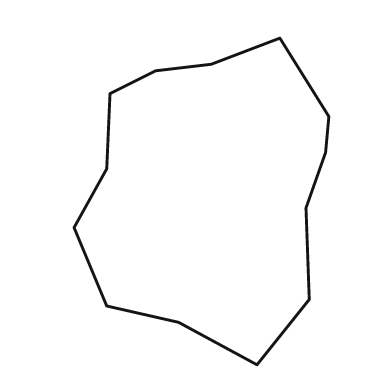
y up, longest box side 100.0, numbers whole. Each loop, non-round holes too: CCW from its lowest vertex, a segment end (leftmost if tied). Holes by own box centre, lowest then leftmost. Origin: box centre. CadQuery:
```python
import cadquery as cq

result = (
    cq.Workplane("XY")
    .moveTo(17.0, -50.0)
    .lineTo(33.0, -30.0)
    .lineTo(32.0, -2.0)
    .lineTo(38.0, 15.0)
    .lineTo(39.0, 26.0)
    .lineTo(24.0, 50.0)
    .lineTo(3.0, 42.0)
    .lineTo(-14.0, 40.0)
    .lineTo(-28.0, 33.0)
    .lineTo(-29.0, 10.0)
    .lineTo(-39.0, -8.0)
    .lineTo(-29.0, -32.0)
    .lineTo(-7.0, -37.0)
    .close()
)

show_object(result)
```